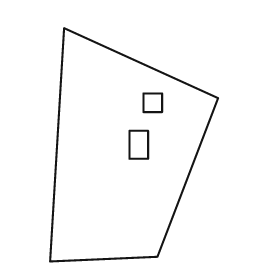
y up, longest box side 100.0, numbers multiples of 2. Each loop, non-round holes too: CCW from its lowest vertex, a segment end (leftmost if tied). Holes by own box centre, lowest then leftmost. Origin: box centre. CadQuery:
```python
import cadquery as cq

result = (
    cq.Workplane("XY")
    .moveTo(-36.0, -50.0)
    .lineTo(10.0, -48.0)
    .lineTo(36.0, 20.0)
    .lineTo(-30.0, 50.0)
    .close()
    .moveTo(-2.0, -6.0)
    .lineTo(6.0, -6.0)
    .lineTo(6.0, 6.0)
    .lineTo(-2.0, 6.0)
    .close()
    .moveTo(4.0, 14.0)
    .lineTo(12.0, 14.0)
    .lineTo(12.0, 22.0)
    .lineTo(4.0, 22.0)
    .close()
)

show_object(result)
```